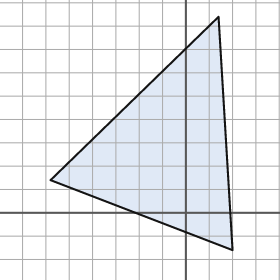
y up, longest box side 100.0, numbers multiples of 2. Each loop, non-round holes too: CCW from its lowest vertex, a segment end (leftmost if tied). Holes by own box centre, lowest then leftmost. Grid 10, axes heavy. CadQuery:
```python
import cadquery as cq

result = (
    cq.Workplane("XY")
    .moveTo(20.0, -16.0)
    .lineTo(14.0, 84.0)
    .lineTo(-58.0, 14.0)
    .close()
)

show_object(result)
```